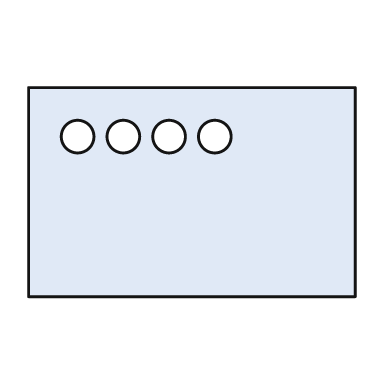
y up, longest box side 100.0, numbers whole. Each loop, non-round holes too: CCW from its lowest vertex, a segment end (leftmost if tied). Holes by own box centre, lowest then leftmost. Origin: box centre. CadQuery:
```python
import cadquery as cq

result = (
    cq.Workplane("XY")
    .moveTo(-50.0, -32.0)
    .lineTo(50.0, -32.0)
    .lineTo(50.0, 32.0)
    .lineTo(-50.0, 32.0)
    .close()
    .moveTo(-35.0, 17.0)
    .circle(5.0)
    .moveTo(-21.0, 17.0)
    .circle(5.0)
    .moveTo(-7.0, 17.0)
    .circle(5.0)
    .moveTo(7.0, 17.0)
    .circle(5.0)
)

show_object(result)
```